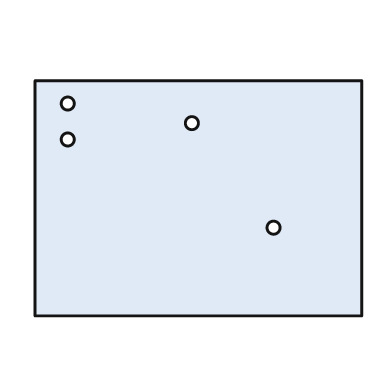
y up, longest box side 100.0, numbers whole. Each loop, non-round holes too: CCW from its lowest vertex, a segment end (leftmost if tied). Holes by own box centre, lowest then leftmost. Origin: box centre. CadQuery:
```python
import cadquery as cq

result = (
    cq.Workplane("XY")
    .moveTo(-50.0, -36.0)
    .lineTo(50.0, -36.0)
    .lineTo(50.0, 36.0)
    .lineTo(-50.0, 36.0)
    .close()
    .moveTo(23.0, -9.0)
    .circle(2.0)
    .moveTo(-40.0, 18.0)
    .circle(2.0)
    .moveTo(-2.0, 23.0)
    .circle(2.0)
    .moveTo(-40.0, 29.0)
    .circle(2.0)
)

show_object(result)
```